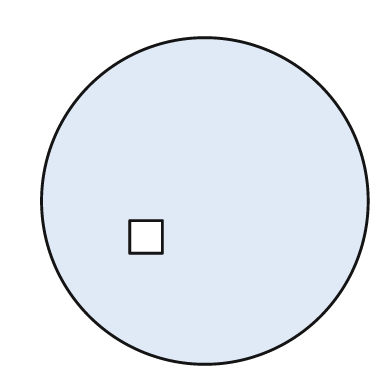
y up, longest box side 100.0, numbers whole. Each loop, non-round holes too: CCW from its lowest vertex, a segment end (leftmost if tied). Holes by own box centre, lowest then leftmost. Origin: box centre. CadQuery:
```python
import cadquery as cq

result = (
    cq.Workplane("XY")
    .moveTo(0.0, 0.0)
    .circle(50.0)
    .moveTo(-23.0, -16.0)
    .lineTo(-13.0, -16.0)
    .lineTo(-13.0, -6.0)
    .lineTo(-23.0, -6.0)
    .close()
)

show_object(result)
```